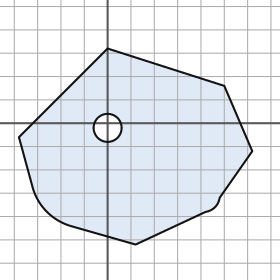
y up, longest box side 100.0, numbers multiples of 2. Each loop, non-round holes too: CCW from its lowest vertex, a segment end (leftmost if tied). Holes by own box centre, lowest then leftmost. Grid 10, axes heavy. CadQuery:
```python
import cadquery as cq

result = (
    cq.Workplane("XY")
    .moveTo(12.0, -52.0)
    .lineTo(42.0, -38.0)
    .threePointArc((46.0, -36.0), (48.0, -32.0))
    .lineTo(62.0, -12.0)
    .lineTo(50.0, 16.0)
    .lineTo(0.0, 32.0)
    .lineTo(-38.0, -6.0)
    .lineTo(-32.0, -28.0)
    .threePointArc((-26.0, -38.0), (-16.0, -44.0))
    .close()
    .moveTo(0.0, -2.0)
    .circle(6.0)
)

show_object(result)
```